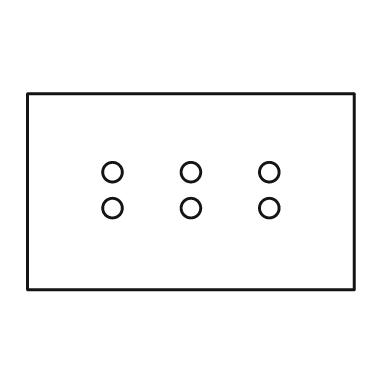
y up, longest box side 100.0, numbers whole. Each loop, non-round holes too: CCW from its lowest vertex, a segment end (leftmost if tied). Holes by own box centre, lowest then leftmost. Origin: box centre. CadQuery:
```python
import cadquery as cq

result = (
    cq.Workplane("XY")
    .moveTo(-50.0, -30.0)
    .lineTo(50.0, -30.0)
    .lineTo(50.0, 30.0)
    .lineTo(-50.0, 30.0)
    .close()
    .moveTo(-24.0, -5.0)
    .circle(3.0)
    .moveTo(0.0, -5.0)
    .circle(3.0)
    .moveTo(24.0, -5.0)
    .circle(3.0)
    .moveTo(-24.0, 6.0)
    .circle(3.0)
    .moveTo(0.0, 6.0)
    .circle(3.0)
    .moveTo(24.0, 6.0)
    .circle(3.0)
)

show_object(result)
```